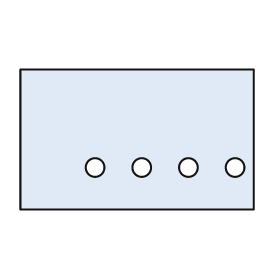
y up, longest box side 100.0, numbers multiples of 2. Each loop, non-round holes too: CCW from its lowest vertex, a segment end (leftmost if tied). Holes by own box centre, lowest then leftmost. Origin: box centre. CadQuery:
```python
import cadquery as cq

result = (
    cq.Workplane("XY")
    .moveTo(-50.0, -30.0)
    .lineTo(50.0, -30.0)
    .lineTo(50.0, 30.0)
    .lineTo(-50.0, 30.0)
    .close()
    .moveTo(-18.0, -12.0)
    .circle(4.0)
    .moveTo(2.0, -12.0)
    .circle(4.0)
    .moveTo(22.0, -12.0)
    .circle(4.0)
    .moveTo(42.0, -12.0)
    .circle(4.0)
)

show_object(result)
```